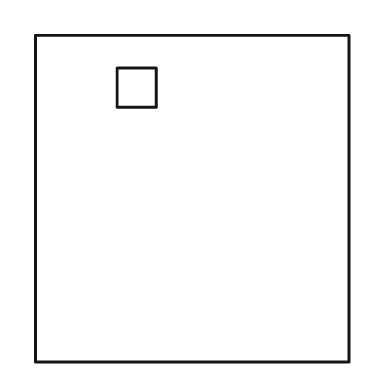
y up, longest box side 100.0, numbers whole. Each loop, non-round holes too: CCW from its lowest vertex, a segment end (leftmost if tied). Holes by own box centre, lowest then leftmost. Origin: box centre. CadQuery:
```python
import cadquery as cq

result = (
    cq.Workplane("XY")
    .moveTo(-48.0, -50.0)
    .lineTo(48.0, -50.0)
    .lineTo(48.0, 50.0)
    .lineTo(-48.0, 50.0)
    .close()
    .moveTo(-23.0, 28.0)
    .lineTo(-11.0, 28.0)
    .lineTo(-11.0, 40.0)
    .lineTo(-23.0, 40.0)
    .close()
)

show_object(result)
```